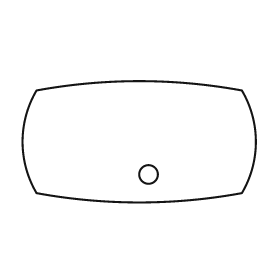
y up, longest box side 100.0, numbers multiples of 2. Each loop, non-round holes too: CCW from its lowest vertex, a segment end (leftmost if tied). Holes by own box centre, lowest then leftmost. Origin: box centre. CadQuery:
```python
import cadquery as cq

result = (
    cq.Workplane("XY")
    .moveTo(-44.0, -22.0)
    .threePointArc((0.0, -26.0), (44.0, -22.0))
    .threePointArc((50.0, 0.0), (44.0, 22.0))
    .threePointArc((0.0, 26.0), (-44.0, 22.0))
    .threePointArc((-50.0, 0.0), (-44.0, -22.0))
    .close()
    .moveTo(4.0, -14.0)
    .circle(4.0)
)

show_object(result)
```